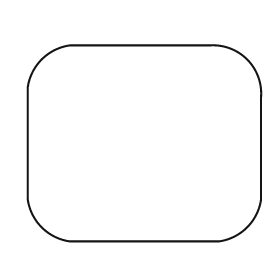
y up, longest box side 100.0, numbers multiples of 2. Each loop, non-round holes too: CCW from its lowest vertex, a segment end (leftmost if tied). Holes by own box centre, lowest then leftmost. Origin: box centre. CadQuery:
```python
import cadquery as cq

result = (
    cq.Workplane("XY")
    .moveTo(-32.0, -42.0)
    .lineTo(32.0, -42.0)
    .threePointArc((44.0, -36.0), (50.0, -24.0))
    .lineTo(50.0, 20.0)
    .threePointArc((44.0, 36.0), (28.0, 42.0))
    .lineTo(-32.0, 42.0)
    .threePointArc((-44.0, 36.0), (-50.0, 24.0))
    .lineTo(-50.0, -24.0)
    .threePointArc((-44.0, -36.0), (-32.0, -42.0))
    .close()
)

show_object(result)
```